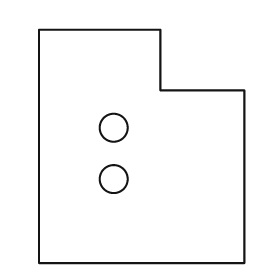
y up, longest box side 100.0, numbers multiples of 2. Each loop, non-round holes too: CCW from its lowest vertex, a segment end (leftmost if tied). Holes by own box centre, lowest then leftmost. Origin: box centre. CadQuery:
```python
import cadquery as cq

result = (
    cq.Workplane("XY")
    .moveTo(-44.0, -50.0)
    .lineTo(44.0, -50.0)
    .lineTo(44.0, 24.0)
    .lineTo(8.0, 24.0)
    .lineTo(8.0, 50.0)
    .lineTo(-44.0, 50.0)
    .close()
    .moveTo(-12.0, -14.0)
    .circle(6.0)
    .moveTo(-12.0, 8.0)
    .circle(6.0)
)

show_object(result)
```